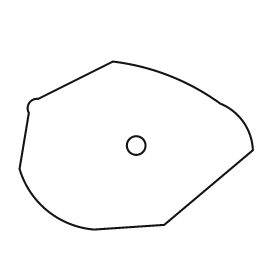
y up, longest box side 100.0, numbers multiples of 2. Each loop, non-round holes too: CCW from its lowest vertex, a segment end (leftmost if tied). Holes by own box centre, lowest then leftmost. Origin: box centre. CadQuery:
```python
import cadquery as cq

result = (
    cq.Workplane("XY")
    .moveTo(-18.0, -36.0)
    .lineTo(12.0, -34.0)
    .lineTo(50.0, -2.0)
    .threePointArc((46.0, 10.0), (36.0, 18.0))
    .threePointArc((14.0, 30.0), (-10.0, 36.0))
    .lineTo(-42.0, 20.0)
    .threePointArc((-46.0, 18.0), (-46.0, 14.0))
    .lineTo(-50.0, -10.0)
    .threePointArc((-38.0, -28.0), (-18.0, -36.0))
    .close()
    .moveTo(0.0, 0.0)
    .circle(4.0)
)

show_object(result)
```